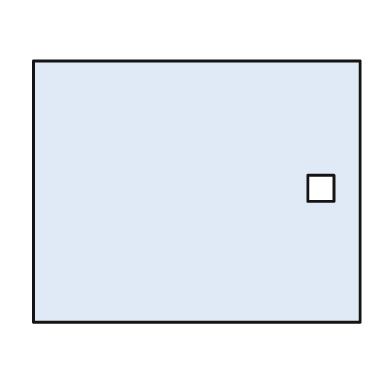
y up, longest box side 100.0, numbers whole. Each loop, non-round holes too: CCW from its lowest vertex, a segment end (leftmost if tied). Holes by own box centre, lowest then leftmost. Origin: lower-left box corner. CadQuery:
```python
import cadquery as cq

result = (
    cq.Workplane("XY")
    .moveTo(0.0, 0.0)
    .lineTo(100.0, 0.0)
    .lineTo(100.0, 80.0)
    .lineTo(0.0, 80.0)
    .close()
    .moveTo(84.0, 37.0)
    .lineTo(92.0, 37.0)
    .lineTo(92.0, 45.0)
    .lineTo(84.0, 45.0)
    .close()
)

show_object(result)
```